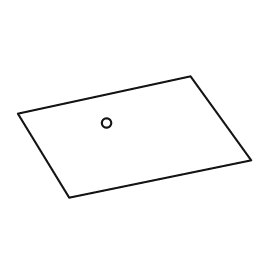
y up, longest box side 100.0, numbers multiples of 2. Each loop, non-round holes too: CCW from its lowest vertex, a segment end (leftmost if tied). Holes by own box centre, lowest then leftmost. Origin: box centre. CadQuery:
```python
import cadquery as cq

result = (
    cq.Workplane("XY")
    .moveTo(-28.0, -26.0)
    .lineTo(50.0, -10.0)
    .lineTo(24.0, 26.0)
    .lineTo(-50.0, 10.0)
    .close()
    .moveTo(-12.0, 6.0)
    .circle(2.0)
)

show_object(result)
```